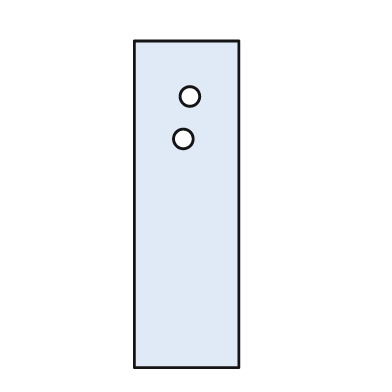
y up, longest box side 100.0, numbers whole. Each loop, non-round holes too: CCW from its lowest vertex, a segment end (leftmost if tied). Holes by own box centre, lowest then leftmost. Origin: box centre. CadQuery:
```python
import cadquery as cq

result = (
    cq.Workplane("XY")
    .moveTo(-16.0, -50.0)
    .lineTo(16.0, -50.0)
    .lineTo(16.0, 50.0)
    .lineTo(-16.0, 50.0)
    .close()
    .moveTo(-1.0, 20.0)
    .circle(3.0)
    .moveTo(1.0, 33.0)
    .circle(3.0)
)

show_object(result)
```